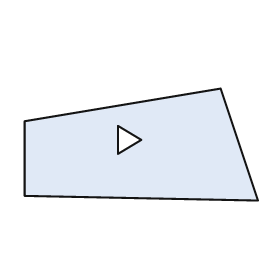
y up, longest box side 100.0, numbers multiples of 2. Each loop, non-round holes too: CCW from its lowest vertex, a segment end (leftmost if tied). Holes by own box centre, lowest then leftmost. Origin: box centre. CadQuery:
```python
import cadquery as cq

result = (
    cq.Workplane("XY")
    .moveTo(50.0, -24.0)
    .lineTo(34.0, 24.0)
    .lineTo(-50.0, 10.0)
    .lineTo(-50.0, -22.0)
    .close()
    .moveTo(-10.0, -4.0)
    .lineTo(0.0, 2.0)
    .lineTo(-10.0, 8.0)
    .close()
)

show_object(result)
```